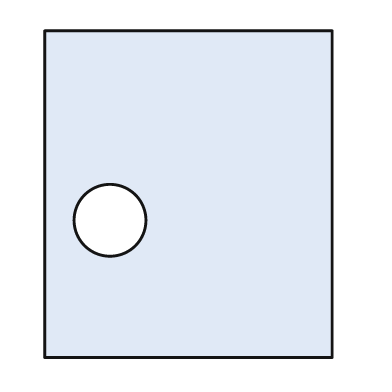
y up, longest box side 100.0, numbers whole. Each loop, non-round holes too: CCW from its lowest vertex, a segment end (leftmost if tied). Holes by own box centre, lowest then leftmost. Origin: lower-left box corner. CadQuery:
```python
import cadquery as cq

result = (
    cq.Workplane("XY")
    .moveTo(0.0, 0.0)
    .lineTo(88.0, 0.0)
    .lineTo(88.0, 100.0)
    .lineTo(0.0, 100.0)
    .close()
    .moveTo(20.0, 42.0)
    .circle(11.0)
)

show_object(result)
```